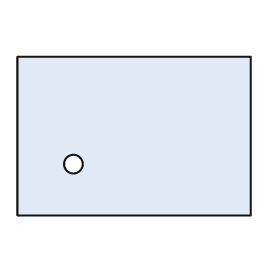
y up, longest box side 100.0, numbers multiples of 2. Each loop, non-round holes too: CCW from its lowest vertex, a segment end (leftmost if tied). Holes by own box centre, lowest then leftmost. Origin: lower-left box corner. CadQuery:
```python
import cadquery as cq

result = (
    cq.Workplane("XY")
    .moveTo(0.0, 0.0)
    .lineTo(100.0, 0.0)
    .lineTo(100.0, 68.0)
    .lineTo(0.0, 68.0)
    .close()
    .moveTo(24.0, 22.0)
    .circle(4.0)
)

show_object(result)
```